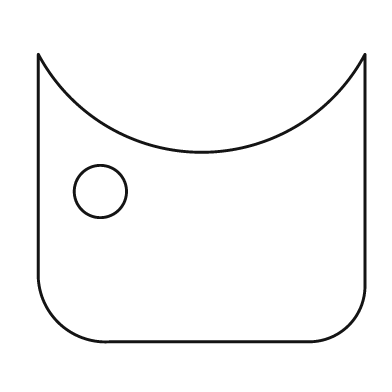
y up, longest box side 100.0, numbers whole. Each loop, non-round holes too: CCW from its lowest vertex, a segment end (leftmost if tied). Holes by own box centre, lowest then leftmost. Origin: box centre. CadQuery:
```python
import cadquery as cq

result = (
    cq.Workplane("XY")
    .moveTo(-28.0, -44.0)
    .lineTo(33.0, -44.0)
    .threePointArc((45.0, -39.0), (50.0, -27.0))
    .lineTo(50.0, 44.0)
    .threePointArc((0.0, 14.0), (-50.0, 44.0))
    .lineTo(-50.0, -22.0)
    .threePointArc((-44.0, -38.0), (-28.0, -44.0))
    .close()
    .moveTo(-31.0, 2.0)
    .circle(8.0)
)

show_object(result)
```